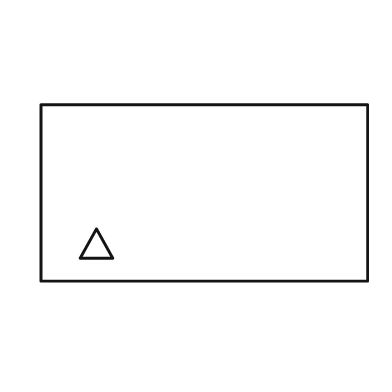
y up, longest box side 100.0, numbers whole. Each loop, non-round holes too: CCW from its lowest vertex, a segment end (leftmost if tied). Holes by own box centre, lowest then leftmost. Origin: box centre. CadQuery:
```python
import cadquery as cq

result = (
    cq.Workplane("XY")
    .moveTo(-50.0, -27.0)
    .lineTo(50.0, -27.0)
    .lineTo(50.0, 27.0)
    .lineTo(-50.0, 27.0)
    .close()
    .moveTo(-38.0, -20.0)
    .lineTo(-28.0, -20.0)
    .lineTo(-33.0, -11.0)
    .close()
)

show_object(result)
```